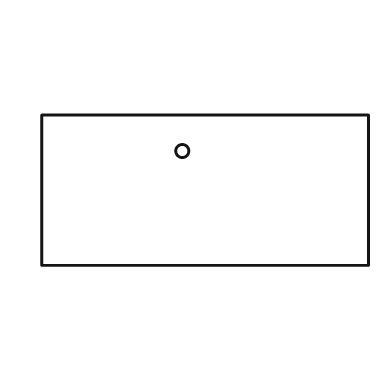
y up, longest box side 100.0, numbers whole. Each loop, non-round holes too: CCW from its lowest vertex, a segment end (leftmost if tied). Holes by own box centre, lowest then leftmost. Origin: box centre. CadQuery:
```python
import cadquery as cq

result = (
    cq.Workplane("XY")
    .moveTo(-50.0, -23.0)
    .lineTo(50.0, -23.0)
    .lineTo(50.0, 23.0)
    .lineTo(-50.0, 23.0)
    .close()
    .moveTo(-7.0, 12.0)
    .circle(2.0)
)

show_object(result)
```